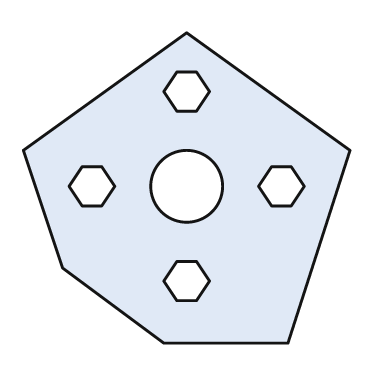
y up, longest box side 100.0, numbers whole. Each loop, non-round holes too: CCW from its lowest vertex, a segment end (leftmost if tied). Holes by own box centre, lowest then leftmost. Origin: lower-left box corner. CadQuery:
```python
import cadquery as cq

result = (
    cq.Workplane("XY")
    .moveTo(43.0, 0.0)
    .lineTo(81.0, 0.0)
    .lineTo(100.0, 59.0)
    .lineTo(50.0, 95.0)
    .lineTo(0.0, 59.0)
    .lineTo(12.0, 23.0)
    .close()
    .moveTo(47.0, 13.0)
    .lineTo(53.0, 13.0)
    .lineTo(57.0, 19.0)
    .lineTo(53.0, 25.0)
    .lineTo(47.0, 25.0)
    .lineTo(43.0, 19.0)
    .close()
    .moveTo(18.0, 42.0)
    .lineTo(24.0, 42.0)
    .lineTo(28.0, 48.0)
    .lineTo(24.0, 54.0)
    .lineTo(18.0, 54.0)
    .lineTo(14.0, 48.0)
    .close()
    .moveTo(50.0, 48.0)
    .circle(11.0)
    .moveTo(76.0, 42.0)
    .lineTo(82.0, 42.0)
    .lineTo(86.0, 48.0)
    .lineTo(82.0, 54.0)
    .lineTo(76.0, 54.0)
    .lineTo(72.0, 48.0)
    .close()
    .moveTo(47.0, 71.0)
    .lineTo(53.0, 71.0)
    .lineTo(57.0, 77.0)
    .lineTo(53.0, 83.0)
    .lineTo(47.0, 83.0)
    .lineTo(43.0, 77.0)
    .close()
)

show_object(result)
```